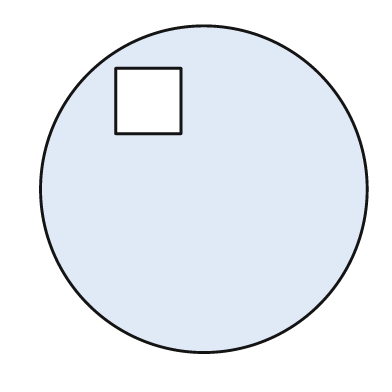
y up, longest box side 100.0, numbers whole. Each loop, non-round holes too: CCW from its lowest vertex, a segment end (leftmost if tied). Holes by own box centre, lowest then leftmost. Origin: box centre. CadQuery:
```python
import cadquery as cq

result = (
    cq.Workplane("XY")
    .moveTo(0.0, 0.0)
    .circle(50.0)
    .moveTo(-27.0, 17.0)
    .lineTo(-7.0, 17.0)
    .lineTo(-7.0, 37.0)
    .lineTo(-27.0, 37.0)
    .close()
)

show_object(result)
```